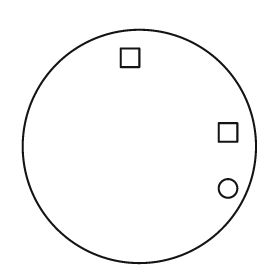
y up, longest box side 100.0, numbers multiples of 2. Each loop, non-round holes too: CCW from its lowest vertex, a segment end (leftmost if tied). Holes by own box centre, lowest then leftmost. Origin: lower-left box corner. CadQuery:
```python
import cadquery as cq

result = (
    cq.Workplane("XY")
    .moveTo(50.0, 50.0)
    .circle(50.0)
    .moveTo(88.0, 32.0)
    .circle(4.0)
    .moveTo(84.0, 52.0)
    .lineTo(92.0, 52.0)
    .lineTo(92.0, 60.0)
    .lineTo(84.0, 60.0)
    .close()
    .moveTo(42.0, 84.0)
    .lineTo(50.0, 84.0)
    .lineTo(50.0, 92.0)
    .lineTo(42.0, 92.0)
    .close()
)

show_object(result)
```